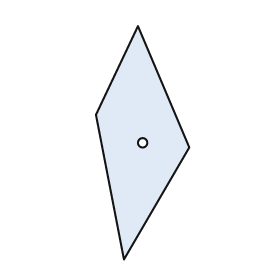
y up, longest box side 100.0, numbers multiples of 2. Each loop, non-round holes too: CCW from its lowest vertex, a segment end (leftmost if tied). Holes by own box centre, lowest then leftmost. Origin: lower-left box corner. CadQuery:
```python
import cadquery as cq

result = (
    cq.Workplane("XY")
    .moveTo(12.0, 0.0)
    .lineTo(40.0, 48.0)
    .lineTo(18.0, 100.0)
    .lineTo(0.0, 62.0)
    .close()
    .moveTo(20.0, 50.0)
    .circle(2.0)
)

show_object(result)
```